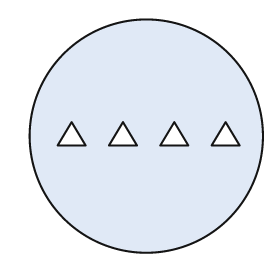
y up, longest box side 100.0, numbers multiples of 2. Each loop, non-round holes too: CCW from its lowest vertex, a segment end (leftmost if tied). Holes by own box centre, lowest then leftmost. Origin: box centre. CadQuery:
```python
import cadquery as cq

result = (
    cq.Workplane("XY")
    .moveTo(0.0, 0.0)
    .circle(50.0)
    .moveTo(-38.0, -4.0)
    .lineTo(-26.0, -4.0)
    .lineTo(-32.0, 6.0)
    .close()
    .moveTo(-16.0, -4.0)
    .lineTo(-4.0, -4.0)
    .lineTo(-10.0, 6.0)
    .close()
    .moveTo(6.0, -4.0)
    .lineTo(18.0, -4.0)
    .lineTo(12.0, 6.0)
    .close()
    .moveTo(28.0, -4.0)
    .lineTo(40.0, -4.0)
    .lineTo(34.0, 6.0)
    .close()
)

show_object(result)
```